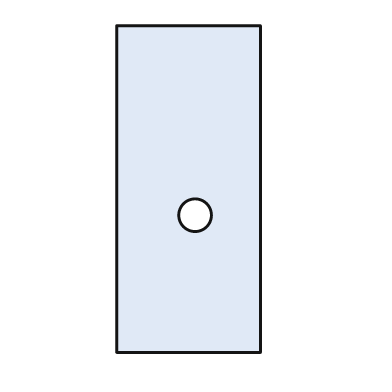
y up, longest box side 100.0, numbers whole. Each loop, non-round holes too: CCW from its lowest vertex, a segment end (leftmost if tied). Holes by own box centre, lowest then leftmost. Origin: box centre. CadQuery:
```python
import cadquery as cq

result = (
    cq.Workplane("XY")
    .moveTo(-22.0, -50.0)
    .lineTo(22.0, -50.0)
    .lineTo(22.0, 50.0)
    .lineTo(-22.0, 50.0)
    .close()
    .moveTo(2.0, -8.0)
    .circle(5.0)
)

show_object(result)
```